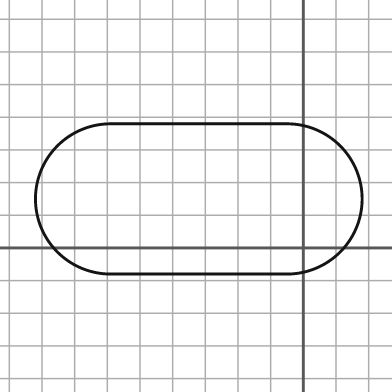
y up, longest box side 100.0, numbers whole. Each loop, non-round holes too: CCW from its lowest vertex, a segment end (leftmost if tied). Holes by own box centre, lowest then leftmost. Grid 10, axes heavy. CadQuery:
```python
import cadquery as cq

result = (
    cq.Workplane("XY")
    .moveTo(-59.0, -8.0)
    .lineTo(-5.0, -8.0)
    .threePointArc((18.0, 15.0), (-5.0, 38.0))
    .lineTo(-59.0, 38.0)
    .threePointArc((-82.0, 15.0), (-59.0, -8.0))
    .close()
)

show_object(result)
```